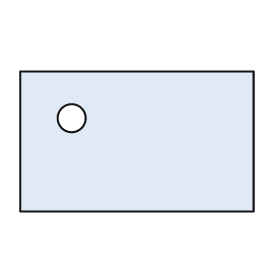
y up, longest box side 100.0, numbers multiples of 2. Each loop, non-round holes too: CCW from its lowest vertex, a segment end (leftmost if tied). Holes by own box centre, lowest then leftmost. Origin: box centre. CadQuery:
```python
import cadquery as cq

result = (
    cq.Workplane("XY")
    .moveTo(-50.0, -30.0)
    .lineTo(50.0, -30.0)
    .lineTo(50.0, 30.0)
    .lineTo(-50.0, 30.0)
    .close()
    .moveTo(-28.0, 10.0)
    .circle(6.0)
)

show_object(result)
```